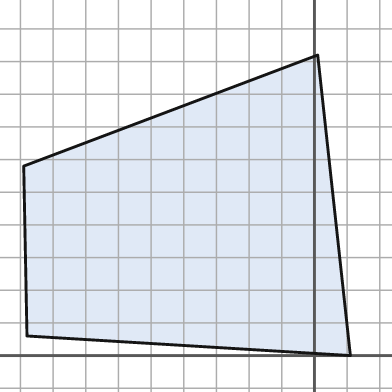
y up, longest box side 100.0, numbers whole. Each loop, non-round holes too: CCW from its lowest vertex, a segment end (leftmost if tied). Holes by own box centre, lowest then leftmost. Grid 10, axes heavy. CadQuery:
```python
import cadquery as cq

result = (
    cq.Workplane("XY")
    .moveTo(11.0, 0.0)
    .lineTo(1.0, 92.0)
    .lineTo(-89.0, 58.0)
    .lineTo(-88.0, 6.0)
    .close()
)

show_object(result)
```